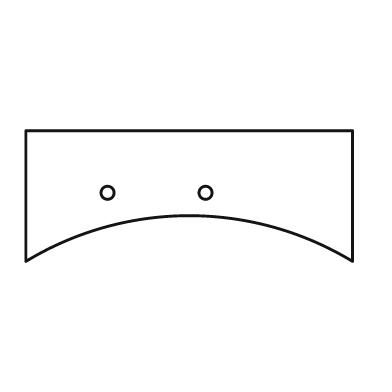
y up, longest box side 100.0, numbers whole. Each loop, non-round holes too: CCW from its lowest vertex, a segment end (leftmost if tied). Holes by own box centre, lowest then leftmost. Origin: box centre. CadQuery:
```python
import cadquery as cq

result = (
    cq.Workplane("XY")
    .moveTo(-50.0, -20.0)
    .threePointArc((0.0, -6.0), (50.0, -20.0))
    .lineTo(50.0, 20.0)
    .lineTo(-50.0, 20.0)
    .close()
    .moveTo(-25.0, 1.0)
    .circle(2.0)
    .moveTo(5.0, 1.0)
    .circle(2.0)
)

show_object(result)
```